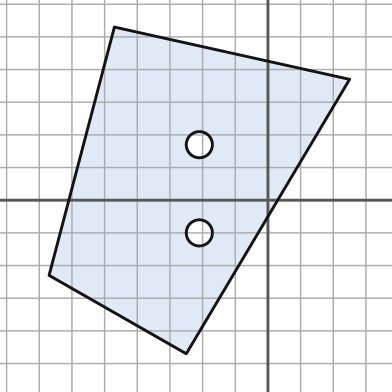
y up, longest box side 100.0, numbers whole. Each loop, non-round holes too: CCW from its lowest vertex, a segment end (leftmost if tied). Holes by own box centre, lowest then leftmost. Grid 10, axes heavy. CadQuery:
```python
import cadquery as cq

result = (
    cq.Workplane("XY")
    .moveTo(-25.0, -47.0)
    .lineTo(25.0, 37.0)
    .lineTo(-47.0, 53.0)
    .lineTo(-67.0, -23.0)
    .close()
    .moveTo(-21.0, -10.0)
    .circle(4.0)
    .moveTo(-21.0, 17.0)
    .circle(4.0)
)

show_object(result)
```